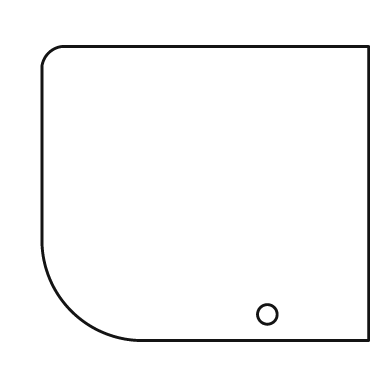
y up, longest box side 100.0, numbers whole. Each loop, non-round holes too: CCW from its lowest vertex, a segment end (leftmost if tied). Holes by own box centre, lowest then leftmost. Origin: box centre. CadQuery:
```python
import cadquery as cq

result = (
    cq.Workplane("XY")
    .moveTo(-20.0, -45.0)
    .lineTo(50.0, -45.0)
    .lineTo(50.0, 45.0)
    .lineTo(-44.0, 45.0)
    .threePointArc((-48.0, 43.0), (-50.0, 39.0))
    .lineTo(-50.0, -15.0)
    .threePointArc((-41.0, -36.0), (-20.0, -45.0))
    .close()
    .moveTo(19.0, -37.0)
    .circle(3.0)
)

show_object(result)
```